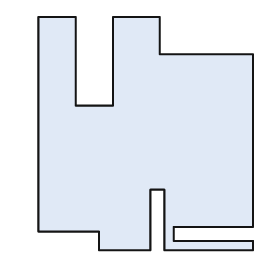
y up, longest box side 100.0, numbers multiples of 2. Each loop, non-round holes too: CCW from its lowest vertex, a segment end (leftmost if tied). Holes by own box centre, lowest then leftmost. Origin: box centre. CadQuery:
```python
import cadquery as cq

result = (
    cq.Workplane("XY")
    .moveTo(-20.0, -50.0)
    .lineTo(2.0, -50.0)
    .lineTo(2.0, -24.0)
    .lineTo(8.0, -24.0)
    .lineTo(8.0, -50.0)
    .lineTo(46.0, -50.0)
    .lineTo(46.0, -46.0)
    .lineTo(12.0, -46.0)
    .lineTo(12.0, -40.0)
    .lineTo(46.0, -40.0)
    .lineTo(46.0, 34.0)
    .lineTo(6.0, 34.0)
    .lineTo(6.0, 50.0)
    .lineTo(-14.0, 50.0)
    .lineTo(-14.0, 12.0)
    .lineTo(-30.0, 12.0)
    .lineTo(-30.0, 50.0)
    .lineTo(-46.0, 50.0)
    .lineTo(-46.0, -42.0)
    .lineTo(-20.0, -42.0)
    .close()
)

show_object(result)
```